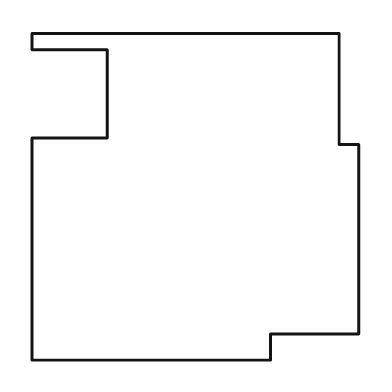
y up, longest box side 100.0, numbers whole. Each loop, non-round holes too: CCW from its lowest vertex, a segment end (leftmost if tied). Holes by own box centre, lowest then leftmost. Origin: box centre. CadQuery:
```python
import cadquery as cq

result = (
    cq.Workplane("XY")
    .moveTo(-50.0, -50.0)
    .lineTo(23.0, -50.0)
    .lineTo(23.0, -42.0)
    .lineTo(50.0, -42.0)
    .lineTo(50.0, 16.0)
    .lineTo(44.0, 16.0)
    .lineTo(44.0, 50.0)
    .lineTo(-50.0, 50.0)
    .lineTo(-50.0, 45.0)
    .lineTo(-27.0, 45.0)
    .lineTo(-27.0, 18.0)
    .lineTo(-50.0, 18.0)
    .close()
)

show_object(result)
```